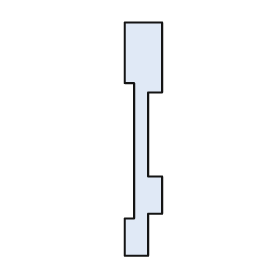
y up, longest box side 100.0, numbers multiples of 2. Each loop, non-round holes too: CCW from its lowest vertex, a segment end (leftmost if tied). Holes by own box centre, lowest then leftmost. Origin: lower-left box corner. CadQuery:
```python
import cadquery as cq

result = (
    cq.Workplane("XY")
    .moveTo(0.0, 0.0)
    .lineTo(10.0, 0.0)
    .lineTo(10.0, 18.0)
    .lineTo(16.0, 18.0)
    .lineTo(16.0, 34.0)
    .lineTo(10.0, 34.0)
    .lineTo(10.0, 70.0)
    .lineTo(16.0, 70.0)
    .lineTo(16.0, 100.0)
    .lineTo(0.0, 100.0)
    .lineTo(0.0, 74.0)
    .lineTo(4.0, 74.0)
    .lineTo(4.0, 16.0)
    .lineTo(0.0, 16.0)
    .close()
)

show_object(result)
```